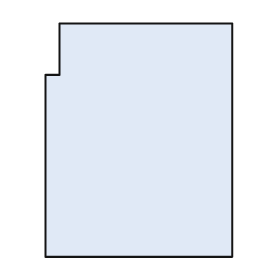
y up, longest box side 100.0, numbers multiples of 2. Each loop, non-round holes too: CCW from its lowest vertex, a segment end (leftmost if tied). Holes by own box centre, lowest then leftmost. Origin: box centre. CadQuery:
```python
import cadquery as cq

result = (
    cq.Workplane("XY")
    .moveTo(-40.0, -50.0)
    .lineTo(40.0, -50.0)
    .lineTo(40.0, 50.0)
    .lineTo(-34.0, 50.0)
    .lineTo(-34.0, 28.0)
    .lineTo(-40.0, 28.0)
    .close()
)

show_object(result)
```